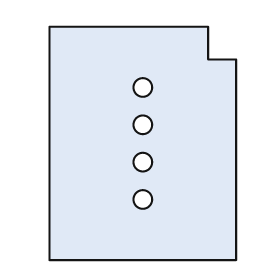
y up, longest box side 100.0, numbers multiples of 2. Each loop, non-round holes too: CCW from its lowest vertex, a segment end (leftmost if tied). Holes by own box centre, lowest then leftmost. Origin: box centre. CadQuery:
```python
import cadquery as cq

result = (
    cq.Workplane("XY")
    .moveTo(-40.0, -50.0)
    .lineTo(40.0, -50.0)
    .lineTo(40.0, 36.0)
    .lineTo(28.0, 36.0)
    .lineTo(28.0, 50.0)
    .lineTo(-40.0, 50.0)
    .close()
    .moveTo(0.0, -24.0)
    .circle(4.0)
    .moveTo(0.0, -8.0)
    .circle(4.0)
    .moveTo(0.0, 8.0)
    .circle(4.0)
    .moveTo(0.0, 24.0)
    .circle(4.0)
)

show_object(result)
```